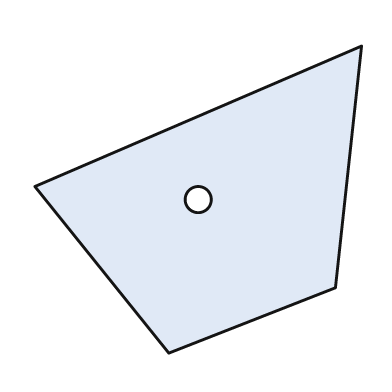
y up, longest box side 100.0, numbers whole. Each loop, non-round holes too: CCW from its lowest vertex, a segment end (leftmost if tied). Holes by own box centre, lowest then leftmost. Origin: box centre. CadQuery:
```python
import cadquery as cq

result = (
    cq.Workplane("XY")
    .moveTo(-9.0, -47.0)
    .lineTo(42.0, -27.0)
    .lineTo(50.0, 47.0)
    .lineTo(-50.0, 4.0)
    .close()
    .moveTo(0.0, 0.0)
    .circle(4.0)
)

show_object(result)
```